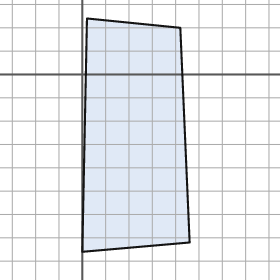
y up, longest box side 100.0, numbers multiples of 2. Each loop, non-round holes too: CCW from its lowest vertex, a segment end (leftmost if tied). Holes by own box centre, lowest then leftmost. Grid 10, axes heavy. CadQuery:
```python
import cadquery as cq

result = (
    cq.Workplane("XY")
    .moveTo(0.0, -76.0)
    .lineTo(46.0, -72.0)
    .lineTo(42.0, 20.0)
    .lineTo(2.0, 24.0)
    .close()
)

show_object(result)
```